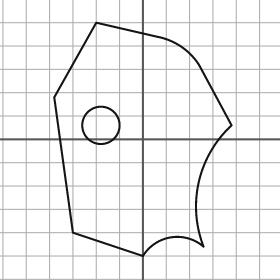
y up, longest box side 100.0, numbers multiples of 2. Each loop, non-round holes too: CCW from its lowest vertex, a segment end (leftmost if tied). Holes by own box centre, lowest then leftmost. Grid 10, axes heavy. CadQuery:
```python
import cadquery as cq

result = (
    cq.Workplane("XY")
    .moveTo(0.0, -50.0)
    .threePointArc((12.0, -42.0), (26.0, -46.0))
    .threePointArc((24.0, -18.0), (38.0, 6.0))
    .lineTo(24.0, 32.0)
    .threePointArc((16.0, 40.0), (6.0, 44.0))
    .lineTo(-20.0, 50.0)
    .lineTo(-38.0, 18.0)
    .lineTo(-30.0, -40.0)
    .close()
    .moveTo(-18.0, 6.0)
    .circle(8.0)
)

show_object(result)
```